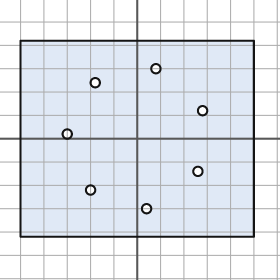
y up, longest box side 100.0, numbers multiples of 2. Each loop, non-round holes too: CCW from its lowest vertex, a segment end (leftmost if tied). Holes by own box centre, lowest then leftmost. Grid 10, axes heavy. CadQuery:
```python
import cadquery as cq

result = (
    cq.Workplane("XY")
    .moveTo(-50.0, -42.0)
    .lineTo(50.0, -42.0)
    .lineTo(50.0, 42.0)
    .lineTo(-50.0, 42.0)
    .close()
    .moveTo(4.0, -30.0)
    .circle(2.0)
    .moveTo(-20.0, -22.0)
    .circle(2.0)
    .moveTo(26.0, -14.0)
    .circle(2.0)
    .moveTo(-30.0, 2.0)
    .circle(2.0)
    .moveTo(28.0, 12.0)
    .circle(2.0)
    .moveTo(-18.0, 24.0)
    .circle(2.0)
    .moveTo(8.0, 30.0)
    .circle(2.0)
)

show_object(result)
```